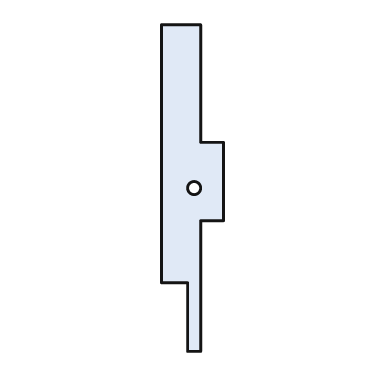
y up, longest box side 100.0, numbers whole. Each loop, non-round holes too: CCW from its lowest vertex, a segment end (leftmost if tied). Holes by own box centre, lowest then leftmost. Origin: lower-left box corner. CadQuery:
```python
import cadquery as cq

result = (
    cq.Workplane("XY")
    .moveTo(8.0, 0.0)
    .lineTo(12.0, 0.0)
    .lineTo(12.0, 40.0)
    .lineTo(19.0, 40.0)
    .lineTo(19.0, 64.0)
    .lineTo(12.0, 64.0)
    .lineTo(12.0, 100.0)
    .lineTo(0.0, 100.0)
    .lineTo(0.0, 21.0)
    .lineTo(8.0, 21.0)
    .close()
    .moveTo(10.0, 50.0)
    .circle(2.0)
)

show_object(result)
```